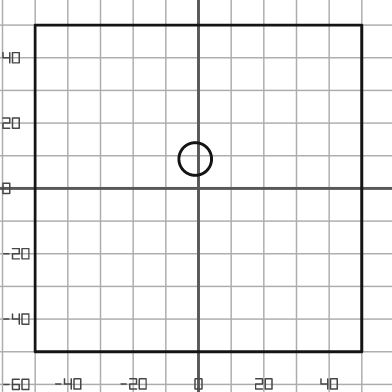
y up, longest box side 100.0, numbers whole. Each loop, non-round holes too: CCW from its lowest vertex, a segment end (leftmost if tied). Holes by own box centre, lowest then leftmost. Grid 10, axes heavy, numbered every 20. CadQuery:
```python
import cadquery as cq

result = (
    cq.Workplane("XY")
    .moveTo(-50.0, -50.0)
    .lineTo(50.0, -50.0)
    .lineTo(50.0, 50.0)
    .lineTo(-50.0, 50.0)
    .close()
    .moveTo(-1.0, 9.0)
    .circle(5.0)
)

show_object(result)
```